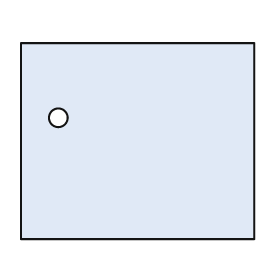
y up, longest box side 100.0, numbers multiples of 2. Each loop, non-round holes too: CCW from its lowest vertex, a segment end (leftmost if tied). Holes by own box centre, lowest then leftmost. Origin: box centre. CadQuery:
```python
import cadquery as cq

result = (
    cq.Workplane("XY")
    .moveTo(-50.0, -42.0)
    .lineTo(50.0, -42.0)
    .lineTo(50.0, 42.0)
    .lineTo(-50.0, 42.0)
    .close()
    .moveTo(-34.0, 10.0)
    .circle(4.0)
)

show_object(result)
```